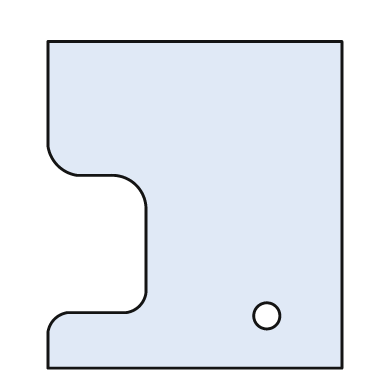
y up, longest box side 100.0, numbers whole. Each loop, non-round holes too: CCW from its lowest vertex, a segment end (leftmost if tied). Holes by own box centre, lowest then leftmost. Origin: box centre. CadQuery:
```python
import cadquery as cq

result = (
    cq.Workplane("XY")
    .moveTo(-45.0, -50.0)
    .lineTo(45.0, -50.0)
    .lineTo(45.0, 50.0)
    .lineTo(-45.0, 50.0)
    .lineTo(-45.0, 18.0)
    .threePointArc((-42.0, 12.0), (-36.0, 9.0))
    .lineTo(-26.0, 9.0)
    .threePointArc((-18.0, 6.0), (-15.0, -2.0))
    .lineTo(-15.0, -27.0)
    .threePointArc((-17.0, -31.0), (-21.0, -33.0))
    .lineTo(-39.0, -33.0)
    .threePointArc((-43.0, -35.0), (-45.0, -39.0))
    .close()
    .moveTo(22.0, -34.0)
    .circle(4.0)
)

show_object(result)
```